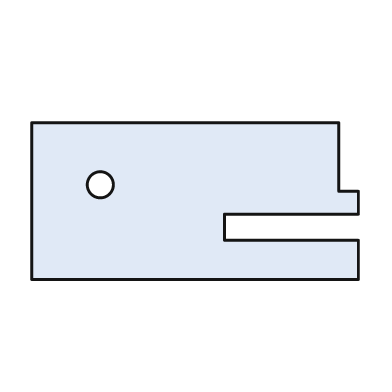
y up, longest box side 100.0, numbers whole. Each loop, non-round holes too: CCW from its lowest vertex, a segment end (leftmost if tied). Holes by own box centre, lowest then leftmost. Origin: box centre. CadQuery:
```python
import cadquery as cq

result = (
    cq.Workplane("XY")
    .moveTo(-50.0, -24.0)
    .lineTo(50.0, -24.0)
    .lineTo(50.0, -12.0)
    .lineTo(9.0, -12.0)
    .lineTo(9.0, -4.0)
    .lineTo(50.0, -4.0)
    .lineTo(50.0, 3.0)
    .lineTo(44.0, 3.0)
    .lineTo(44.0, 24.0)
    .lineTo(-50.0, 24.0)
    .close()
    .moveTo(-29.0, 5.0)
    .circle(4.0)
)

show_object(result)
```